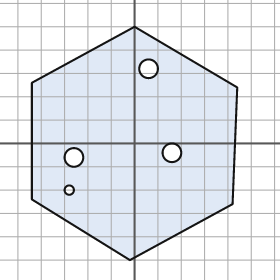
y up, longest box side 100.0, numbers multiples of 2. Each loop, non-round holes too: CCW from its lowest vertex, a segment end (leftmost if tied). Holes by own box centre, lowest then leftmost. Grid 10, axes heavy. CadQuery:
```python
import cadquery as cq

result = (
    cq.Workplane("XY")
    .moveTo(-2.0, -50.0)
    .lineTo(42.0, -26.0)
    .lineTo(44.0, 24.0)
    .lineTo(0.0, 50.0)
    .lineTo(-44.0, 26.0)
    .lineTo(-44.0, -24.0)
    .close()
    .moveTo(-28.0, -20.0)
    .circle(2.0)
    .moveTo(-26.0, -6.0)
    .circle(4.0)
    .moveTo(16.0, -4.0)
    .circle(4.0)
    .moveTo(6.0, 32.0)
    .circle(4.0)
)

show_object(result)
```